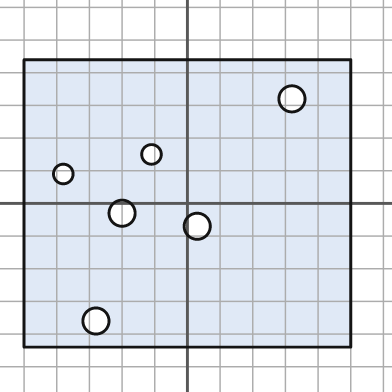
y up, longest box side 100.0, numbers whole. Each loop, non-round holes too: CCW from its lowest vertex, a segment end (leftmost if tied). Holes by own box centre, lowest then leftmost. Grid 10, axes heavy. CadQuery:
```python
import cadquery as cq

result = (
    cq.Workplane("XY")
    .moveTo(-50.0, -44.0)
    .lineTo(50.0, -44.0)
    .lineTo(50.0, 44.0)
    .lineTo(-50.0, 44.0)
    .close()
    .moveTo(-28.0, -36.0)
    .circle(4.0)
    .moveTo(3.0, -7.0)
    .circle(4.0)
    .moveTo(-20.0, -3.0)
    .circle(4.0)
    .moveTo(-38.0, 9.0)
    .circle(3.0)
    .moveTo(-11.0, 15.0)
    .circle(3.0)
    .moveTo(32.0, 32.0)
    .circle(4.0)
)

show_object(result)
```